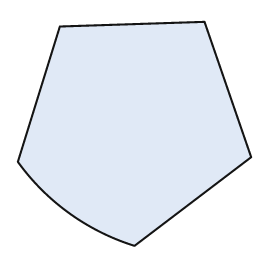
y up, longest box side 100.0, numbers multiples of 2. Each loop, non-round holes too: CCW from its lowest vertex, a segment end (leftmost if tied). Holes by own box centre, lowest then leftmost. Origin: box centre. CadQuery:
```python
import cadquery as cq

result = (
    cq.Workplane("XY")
    .moveTo(0.0, -48.0)
    .lineTo(50.0, -10.0)
    .lineTo(30.0, 48.0)
    .lineTo(-32.0, 46.0)
    .lineTo(-50.0, -12.0)
    .threePointArc((-28.0, -34.0), (0.0, -48.0))
    .close()
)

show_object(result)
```